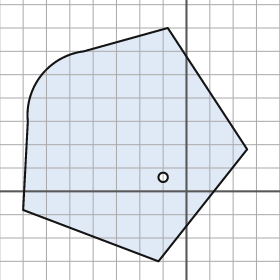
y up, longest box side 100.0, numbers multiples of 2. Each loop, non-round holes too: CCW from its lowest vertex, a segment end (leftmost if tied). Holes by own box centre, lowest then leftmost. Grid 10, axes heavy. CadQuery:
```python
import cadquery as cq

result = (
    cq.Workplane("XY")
    .moveTo(-12.0, -30.0)
    .lineTo(26.0, 18.0)
    .lineTo(-8.0, 70.0)
    .lineTo(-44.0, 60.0)
    .threePointArc((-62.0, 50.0), (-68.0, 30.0))
    .lineTo(-70.0, -8.0)
    .close()
    .moveTo(-10.0, 6.0)
    .circle(2.0)
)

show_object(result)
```